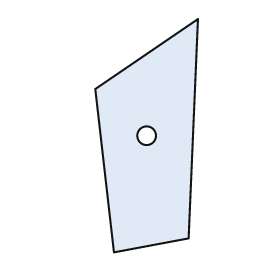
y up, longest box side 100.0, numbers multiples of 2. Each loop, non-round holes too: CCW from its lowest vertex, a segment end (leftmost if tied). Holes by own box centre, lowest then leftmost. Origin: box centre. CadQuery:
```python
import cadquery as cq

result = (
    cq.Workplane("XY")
    .moveTo(-14.0, -50.0)
    .lineTo(18.0, -44.0)
    .lineTo(22.0, 50.0)
    .lineTo(-22.0, 20.0)
    .close()
    .moveTo(0.0, 0.0)
    .circle(4.0)
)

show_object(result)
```